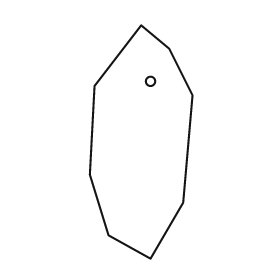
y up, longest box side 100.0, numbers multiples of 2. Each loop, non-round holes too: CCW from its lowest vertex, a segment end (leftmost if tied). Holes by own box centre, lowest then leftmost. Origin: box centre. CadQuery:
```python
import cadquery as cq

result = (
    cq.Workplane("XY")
    .moveTo(4.0, -50.0)
    .lineTo(18.0, -26.0)
    .lineTo(22.0, 20.0)
    .lineTo(12.0, 40.0)
    .lineTo(0.0, 50.0)
    .lineTo(-20.0, 24.0)
    .lineTo(-22.0, -14.0)
    .lineTo(-14.0, -40.0)
    .close()
    .moveTo(4.0, 26.0)
    .circle(2.0)
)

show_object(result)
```